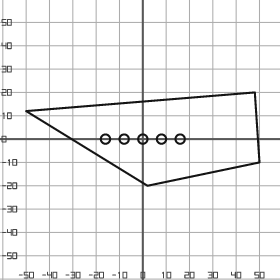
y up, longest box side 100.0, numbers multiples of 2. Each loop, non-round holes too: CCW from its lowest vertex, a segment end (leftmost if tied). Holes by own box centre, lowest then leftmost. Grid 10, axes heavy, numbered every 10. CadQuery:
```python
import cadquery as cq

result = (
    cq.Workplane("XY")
    .moveTo(2.0, -20.0)
    .lineTo(50.0, -10.0)
    .lineTo(48.0, 20.0)
    .lineTo(-50.0, 12.0)
    .close()
    .moveTo(-16.0, 0.0)
    .circle(2.0)
    .moveTo(-8.0, 0.0)
    .circle(2.0)
    .moveTo(0.0, 0.0)
    .circle(2.0)
    .moveTo(8.0, 0.0)
    .circle(2.0)
    .moveTo(16.0, 0.0)
    .circle(2.0)
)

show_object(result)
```